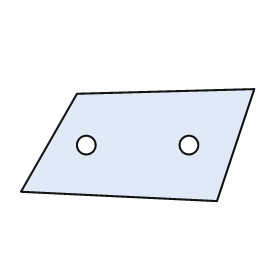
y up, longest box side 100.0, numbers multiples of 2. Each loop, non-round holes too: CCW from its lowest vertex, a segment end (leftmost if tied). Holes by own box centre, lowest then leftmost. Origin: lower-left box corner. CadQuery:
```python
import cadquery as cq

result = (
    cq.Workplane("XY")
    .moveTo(84.0, 0.0)
    .lineTo(100.0, 48.0)
    .lineTo(24.0, 46.0)
    .lineTo(0.0, 4.0)
    .close()
    .moveTo(28.0, 24.0)
    .circle(4.0)
    .moveTo(72.0, 24.0)
    .circle(4.0)
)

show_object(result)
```